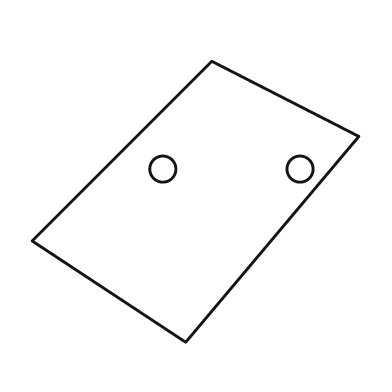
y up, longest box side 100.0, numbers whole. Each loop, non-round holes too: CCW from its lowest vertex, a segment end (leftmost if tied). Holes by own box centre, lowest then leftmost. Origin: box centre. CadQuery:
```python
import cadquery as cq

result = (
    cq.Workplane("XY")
    .moveTo(-3.0, -43.0)
    .lineTo(50.0, 20.0)
    .lineTo(5.0, 43.0)
    .lineTo(-50.0, -12.0)
    .close()
    .moveTo(-10.0, 10.0)
    .circle(4.0)
    .moveTo(32.0, 10.0)
    .circle(4.0)
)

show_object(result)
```